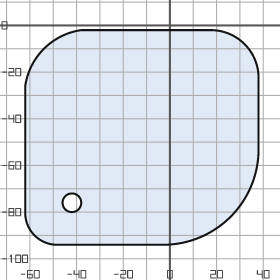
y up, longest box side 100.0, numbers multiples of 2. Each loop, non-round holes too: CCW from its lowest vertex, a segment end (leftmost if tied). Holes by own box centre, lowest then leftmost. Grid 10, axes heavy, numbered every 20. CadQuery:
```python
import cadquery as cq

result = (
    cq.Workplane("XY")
    .moveTo(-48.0, -94.0)
    .lineTo(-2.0, -94.0)
    .threePointArc((26.0, -82.0), (38.0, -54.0))
    .lineTo(38.0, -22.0)
    .threePointArc((32.0, -8.0), (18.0, -2.0))
    .lineTo(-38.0, -2.0)
    .threePointArc((-54.0, -10.0), (-62.0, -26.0))
    .lineTo(-62.0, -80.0)
    .threePointArc((-58.0, -90.0), (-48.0, -94.0))
    .close()
    .moveTo(-42.0, -76.0)
    .circle(4.0)
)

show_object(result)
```